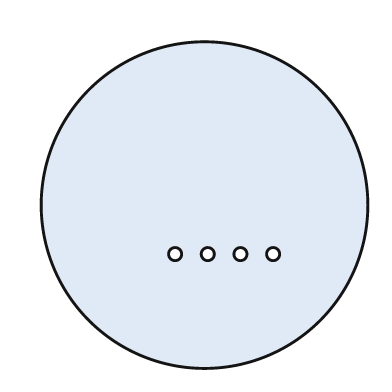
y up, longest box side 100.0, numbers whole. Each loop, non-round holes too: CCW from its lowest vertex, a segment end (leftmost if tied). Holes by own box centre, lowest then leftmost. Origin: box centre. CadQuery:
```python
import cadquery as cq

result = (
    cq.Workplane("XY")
    .moveTo(0.0, 0.0)
    .circle(50.0)
    .moveTo(-9.0, -15.0)
    .circle(2.0)
    .moveTo(1.0, -15.0)
    .circle(2.0)
    .moveTo(11.0, -15.0)
    .circle(2.0)
    .moveTo(21.0, -15.0)
    .circle(2.0)
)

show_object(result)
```